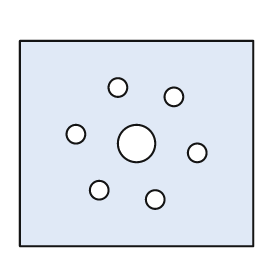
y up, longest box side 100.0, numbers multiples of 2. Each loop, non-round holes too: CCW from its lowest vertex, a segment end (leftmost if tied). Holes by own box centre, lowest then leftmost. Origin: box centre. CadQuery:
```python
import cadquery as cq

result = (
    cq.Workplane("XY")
    .moveTo(-50.0, -44.0)
    .lineTo(50.0, -44.0)
    .lineTo(50.0, 44.0)
    .lineTo(-50.0, 44.0)
    .close()
    .moveTo(8.0, -24.0)
    .circle(4.0)
    .moveTo(-16.0, -20.0)
    .circle(4.0)
    .moveTo(26.0, -4.0)
    .circle(4.0)
    .moveTo(0.0, 0.0)
    .circle(8.0)
    .moveTo(-26.0, 4.0)
    .circle(4.0)
    .moveTo(16.0, 20.0)
    .circle(4.0)
    .moveTo(-8.0, 24.0)
    .circle(4.0)
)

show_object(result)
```